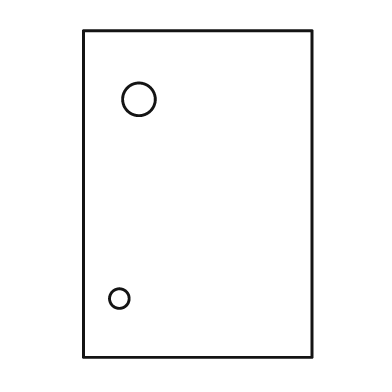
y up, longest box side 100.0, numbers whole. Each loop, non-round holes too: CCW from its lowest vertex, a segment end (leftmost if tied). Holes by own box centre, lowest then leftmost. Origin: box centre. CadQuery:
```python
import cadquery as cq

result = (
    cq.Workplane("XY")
    .moveTo(-35.0, -50.0)
    .lineTo(35.0, -50.0)
    .lineTo(35.0, 50.0)
    .lineTo(-35.0, 50.0)
    .close()
    .moveTo(-24.0, -32.0)
    .circle(3.0)
    .moveTo(-18.0, 29.0)
    .circle(5.0)
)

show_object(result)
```